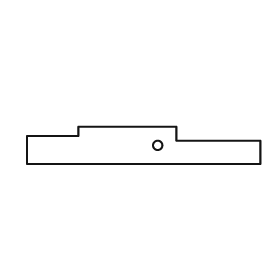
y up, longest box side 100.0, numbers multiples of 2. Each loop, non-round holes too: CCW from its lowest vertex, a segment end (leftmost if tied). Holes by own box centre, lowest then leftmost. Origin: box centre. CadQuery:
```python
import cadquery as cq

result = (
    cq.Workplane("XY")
    .moveTo(-50.0, -8.0)
    .lineTo(50.0, -8.0)
    .lineTo(50.0, 2.0)
    .lineTo(14.0, 2.0)
    .lineTo(14.0, 8.0)
    .lineTo(-28.0, 8.0)
    .lineTo(-28.0, 4.0)
    .lineTo(-50.0, 4.0)
    .close()
    .moveTo(6.0, 0.0)
    .circle(2.0)
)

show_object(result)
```